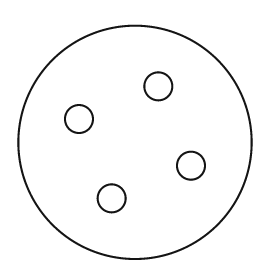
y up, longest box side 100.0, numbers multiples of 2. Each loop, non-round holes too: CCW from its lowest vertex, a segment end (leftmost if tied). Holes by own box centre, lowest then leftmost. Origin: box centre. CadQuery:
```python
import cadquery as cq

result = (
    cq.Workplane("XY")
    .moveTo(0.0, 0.0)
    .circle(50.0)
    .moveTo(-10.0, -24.0)
    .circle(6.0)
    .moveTo(24.0, -10.0)
    .circle(6.0)
    .moveTo(-24.0, 10.0)
    .circle(6.0)
    .moveTo(10.0, 24.0)
    .circle(6.0)
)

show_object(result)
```